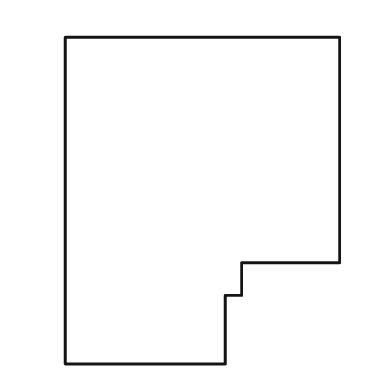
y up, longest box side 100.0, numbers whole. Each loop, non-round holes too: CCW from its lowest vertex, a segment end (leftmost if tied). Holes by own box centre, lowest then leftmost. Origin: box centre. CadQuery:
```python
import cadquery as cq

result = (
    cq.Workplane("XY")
    .moveTo(-42.0, -50.0)
    .lineTo(7.0, -50.0)
    .lineTo(7.0, -29.0)
    .lineTo(12.0, -29.0)
    .lineTo(12.0, -19.0)
    .lineTo(42.0, -19.0)
    .lineTo(42.0, 50.0)
    .lineTo(-42.0, 50.0)
    .close()
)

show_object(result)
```